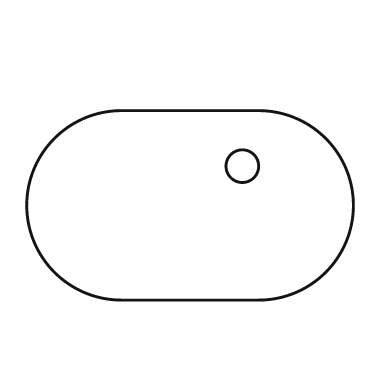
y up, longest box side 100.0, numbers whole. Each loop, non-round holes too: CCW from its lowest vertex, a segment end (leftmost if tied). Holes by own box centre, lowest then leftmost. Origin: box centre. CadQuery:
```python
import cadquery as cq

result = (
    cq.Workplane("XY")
    .moveTo(-21.0, -29.0)
    .lineTo(21.0, -29.0)
    .threePointArc((50.0, 0.0), (21.0, 29.0))
    .lineTo(-21.0, 29.0)
    .threePointArc((-50.0, 0.0), (-21.0, -29.0))
    .close()
    .moveTo(16.0, 12.0)
    .circle(5.0)
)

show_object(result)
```